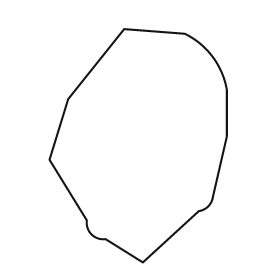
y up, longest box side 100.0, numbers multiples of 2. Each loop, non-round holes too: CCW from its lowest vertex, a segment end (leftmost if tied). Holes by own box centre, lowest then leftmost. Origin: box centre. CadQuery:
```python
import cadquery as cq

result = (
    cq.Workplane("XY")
    .moveTo(2.0, -50.0)
    .lineTo(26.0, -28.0)
    .threePointArc((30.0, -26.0), (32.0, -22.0))
    .lineTo(38.0, 4.0)
    .lineTo(38.0, 24.0)
    .threePointArc((32.0, 38.0), (20.0, 48.0))
    .lineTo(-6.0, 50.0)
    .lineTo(-30.0, 20.0)
    .lineTo(-38.0, -6.0)
    .lineTo(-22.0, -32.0)
    .threePointArc((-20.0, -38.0), (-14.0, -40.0))
    .close()
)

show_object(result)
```